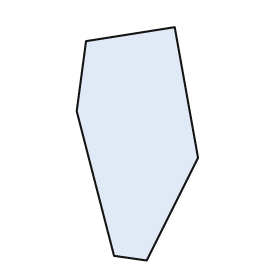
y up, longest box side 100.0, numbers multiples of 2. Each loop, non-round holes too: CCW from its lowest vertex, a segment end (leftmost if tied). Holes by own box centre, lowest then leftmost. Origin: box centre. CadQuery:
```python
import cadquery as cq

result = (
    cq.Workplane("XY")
    .moveTo(4.0, -50.0)
    .lineTo(26.0, -6.0)
    .lineTo(16.0, 50.0)
    .lineTo(-22.0, 44.0)
    .lineTo(-26.0, 14.0)
    .lineTo(-10.0, -48.0)
    .close()
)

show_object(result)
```